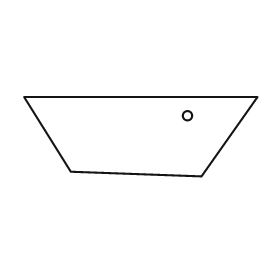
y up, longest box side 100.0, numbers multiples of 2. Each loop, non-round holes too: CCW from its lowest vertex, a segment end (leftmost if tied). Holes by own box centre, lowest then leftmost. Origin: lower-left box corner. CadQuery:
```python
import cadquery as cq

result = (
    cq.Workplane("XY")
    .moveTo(76.0, 0.0)
    .lineTo(100.0, 34.0)
    .lineTo(0.0, 34.0)
    .lineTo(20.0, 2.0)
    .close()
    .moveTo(70.0, 26.0)
    .circle(2.0)
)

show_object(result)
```